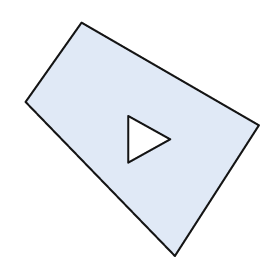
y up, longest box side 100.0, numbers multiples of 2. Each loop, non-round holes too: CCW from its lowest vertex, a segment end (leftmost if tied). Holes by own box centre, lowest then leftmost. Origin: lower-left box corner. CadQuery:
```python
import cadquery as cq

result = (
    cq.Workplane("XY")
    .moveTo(64.0, 0.0)
    .lineTo(100.0, 56.0)
    .lineTo(24.0, 100.0)
    .lineTo(0.0, 66.0)
    .close()
    .moveTo(44.0, 40.0)
    .lineTo(62.0, 50.0)
    .lineTo(44.0, 60.0)
    .close()
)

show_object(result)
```